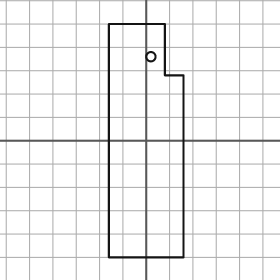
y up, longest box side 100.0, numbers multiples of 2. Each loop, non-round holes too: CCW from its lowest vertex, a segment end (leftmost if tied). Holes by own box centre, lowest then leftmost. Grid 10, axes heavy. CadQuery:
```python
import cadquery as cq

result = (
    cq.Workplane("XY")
    .moveTo(-16.0, -50.0)
    .lineTo(16.0, -50.0)
    .lineTo(16.0, 28.0)
    .lineTo(8.0, 28.0)
    .lineTo(8.0, 50.0)
    .lineTo(-16.0, 50.0)
    .close()
    .moveTo(2.0, 36.0)
    .circle(2.0)
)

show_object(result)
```